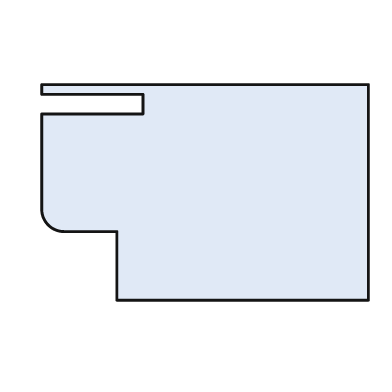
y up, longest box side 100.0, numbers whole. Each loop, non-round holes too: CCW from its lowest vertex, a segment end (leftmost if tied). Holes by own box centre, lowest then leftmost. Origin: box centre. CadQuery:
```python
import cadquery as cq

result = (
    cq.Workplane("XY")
    .moveTo(-27.0, -33.0)
    .lineTo(50.0, -33.0)
    .lineTo(50.0, 33.0)
    .lineTo(-50.0, 33.0)
    .lineTo(-50.0, 30.0)
    .lineTo(-19.0, 30.0)
    .lineTo(-19.0, 24.0)
    .lineTo(-50.0, 24.0)
    .lineTo(-50.0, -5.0)
    .threePointArc((-48.0, -10.0), (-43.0, -12.0))
    .lineTo(-27.0, -12.0)
    .close()
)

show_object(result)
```